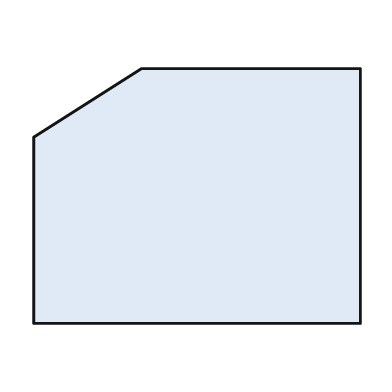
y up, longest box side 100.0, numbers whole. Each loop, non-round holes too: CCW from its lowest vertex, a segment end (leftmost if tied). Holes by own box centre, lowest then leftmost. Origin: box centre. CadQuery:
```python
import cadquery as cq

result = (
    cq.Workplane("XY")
    .moveTo(-50.0, -39.0)
    .lineTo(50.0, -39.0)
    .lineTo(50.0, 39.0)
    .lineTo(-17.0, 39.0)
    .lineTo(-50.0, 18.0)
    .close()
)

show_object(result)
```